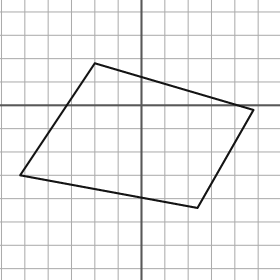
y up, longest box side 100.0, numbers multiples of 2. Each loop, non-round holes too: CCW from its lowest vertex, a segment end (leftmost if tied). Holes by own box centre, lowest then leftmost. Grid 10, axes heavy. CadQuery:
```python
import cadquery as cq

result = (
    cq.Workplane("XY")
    .moveTo(24.0, -44.0)
    .lineTo(48.0, -2.0)
    .lineTo(-20.0, 18.0)
    .lineTo(-52.0, -30.0)
    .close()
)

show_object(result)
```